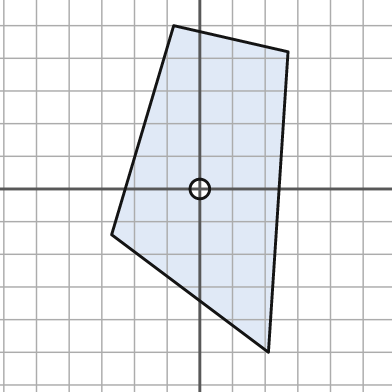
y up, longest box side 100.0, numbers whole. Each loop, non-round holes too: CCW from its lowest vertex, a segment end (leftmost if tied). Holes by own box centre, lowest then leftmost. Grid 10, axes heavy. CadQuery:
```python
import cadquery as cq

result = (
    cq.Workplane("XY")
    .moveTo(21.0, -50.0)
    .lineTo(27.0, 42.0)
    .lineTo(-8.0, 50.0)
    .lineTo(-27.0, -14.0)
    .close()
    .moveTo(0.0, 0.0)
    .circle(3.0)
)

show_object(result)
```